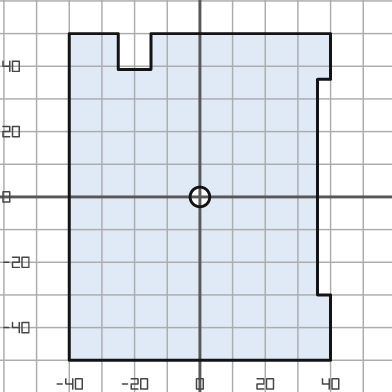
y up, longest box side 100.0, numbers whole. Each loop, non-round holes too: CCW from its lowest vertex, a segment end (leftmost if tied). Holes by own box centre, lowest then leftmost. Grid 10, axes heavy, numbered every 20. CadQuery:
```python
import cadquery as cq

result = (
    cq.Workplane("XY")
    .moveTo(-40.0, -50.0)
    .lineTo(40.0, -50.0)
    .lineTo(40.0, -30.0)
    .lineTo(36.0, -30.0)
    .lineTo(36.0, 36.0)
    .lineTo(40.0, 36.0)
    .lineTo(40.0, 50.0)
    .lineTo(-15.0, 50.0)
    .lineTo(-15.0, 39.0)
    .lineTo(-25.0, 39.0)
    .lineTo(-25.0, 50.0)
    .lineTo(-40.0, 50.0)
    .close()
    .moveTo(0.0, 0.0)
    .circle(3.0)
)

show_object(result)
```